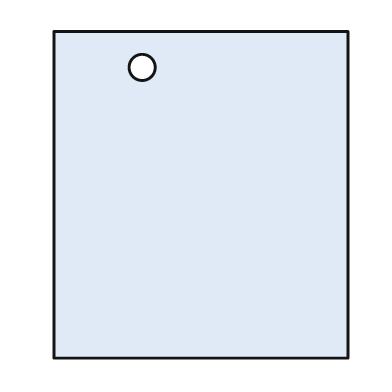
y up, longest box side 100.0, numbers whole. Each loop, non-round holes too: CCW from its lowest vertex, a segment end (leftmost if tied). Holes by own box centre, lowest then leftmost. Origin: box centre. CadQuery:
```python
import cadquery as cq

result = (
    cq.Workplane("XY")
    .moveTo(-45.0, -50.0)
    .lineTo(45.0, -50.0)
    .lineTo(45.0, 50.0)
    .lineTo(-45.0, 50.0)
    .close()
    .moveTo(-18.0, 39.0)
    .circle(4.0)
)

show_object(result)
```